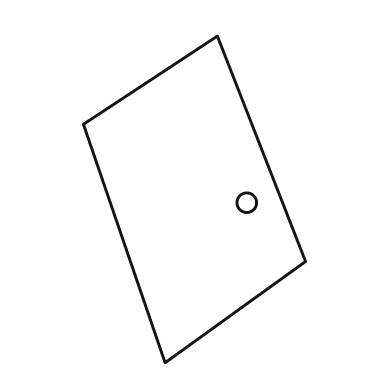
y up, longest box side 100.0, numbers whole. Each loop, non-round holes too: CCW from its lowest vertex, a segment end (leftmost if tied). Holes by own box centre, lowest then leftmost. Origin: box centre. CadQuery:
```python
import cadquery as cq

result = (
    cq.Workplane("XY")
    .moveTo(-9.0, -50.0)
    .lineTo(34.0, -19.0)
    .lineTo(7.0, 50.0)
    .lineTo(-34.0, 23.0)
    .close()
    .moveTo(16.0, -1.0)
    .circle(3.0)
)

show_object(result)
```